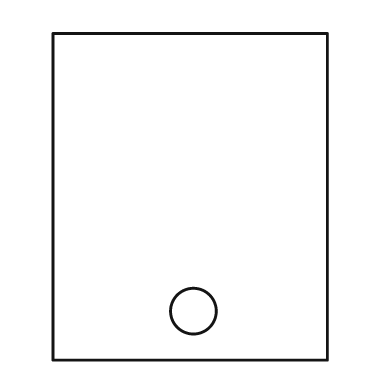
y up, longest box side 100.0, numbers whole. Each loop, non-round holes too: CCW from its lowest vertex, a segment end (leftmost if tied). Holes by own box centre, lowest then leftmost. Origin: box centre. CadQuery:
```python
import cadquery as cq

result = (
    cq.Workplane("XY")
    .moveTo(-42.0, -50.0)
    .lineTo(42.0, -50.0)
    .lineTo(42.0, 50.0)
    .lineTo(-42.0, 50.0)
    .close()
    .moveTo(1.0, -35.0)
    .circle(7.0)
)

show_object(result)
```